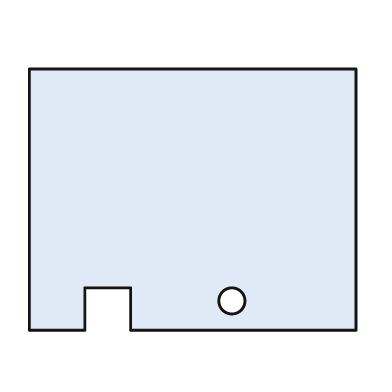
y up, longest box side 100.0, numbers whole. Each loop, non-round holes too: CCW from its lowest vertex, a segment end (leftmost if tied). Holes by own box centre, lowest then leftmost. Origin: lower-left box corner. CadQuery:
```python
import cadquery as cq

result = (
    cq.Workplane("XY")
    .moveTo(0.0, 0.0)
    .lineTo(17.0, 0.0)
    .lineTo(17.0, 13.0)
    .lineTo(31.0, 13.0)
    .lineTo(31.0, 0.0)
    .lineTo(100.0, 0.0)
    .lineTo(100.0, 80.0)
    .lineTo(0.0, 80.0)
    .close()
    .moveTo(62.0, 9.0)
    .circle(4.0)
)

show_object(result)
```